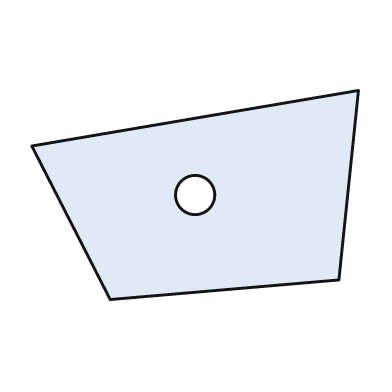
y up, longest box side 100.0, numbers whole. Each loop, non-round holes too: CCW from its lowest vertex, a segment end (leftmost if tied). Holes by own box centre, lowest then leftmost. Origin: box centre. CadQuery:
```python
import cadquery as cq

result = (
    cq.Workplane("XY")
    .moveTo(-26.0, -32.0)
    .lineTo(44.0, -26.0)
    .lineTo(50.0, 32.0)
    .lineTo(-50.0, 15.0)
    .close()
    .moveTo(0.0, 0.0)
    .circle(6.0)
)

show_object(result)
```